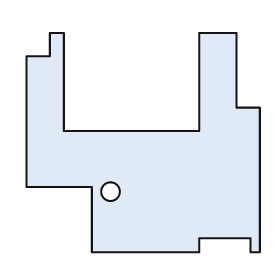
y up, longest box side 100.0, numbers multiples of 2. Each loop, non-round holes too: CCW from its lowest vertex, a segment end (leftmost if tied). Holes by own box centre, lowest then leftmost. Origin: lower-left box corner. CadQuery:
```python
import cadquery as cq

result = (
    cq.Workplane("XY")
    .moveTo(28.0, 0.0)
    .lineTo(74.0, 0.0)
    .lineTo(74.0, 6.0)
    .lineTo(96.0, 6.0)
    .lineTo(96.0, 0.0)
    .lineTo(100.0, 0.0)
    .lineTo(100.0, 62.0)
    .lineTo(90.0, 62.0)
    .lineTo(90.0, 94.0)
    .lineTo(74.0, 94.0)
    .lineTo(74.0, 52.0)
    .lineTo(16.0, 52.0)
    .lineTo(16.0, 94.0)
    .lineTo(10.0, 94.0)
    .lineTo(10.0, 84.0)
    .lineTo(0.0, 84.0)
    .lineTo(0.0, 28.0)
    .lineTo(28.0, 28.0)
    .close()
    .moveTo(36.0, 26.0)
    .circle(4.0)
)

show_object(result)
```